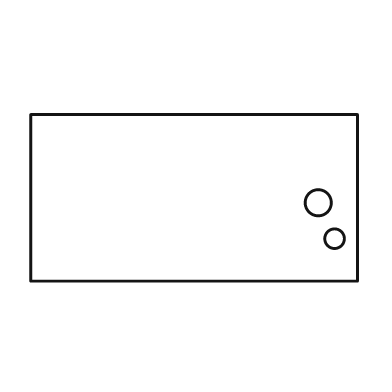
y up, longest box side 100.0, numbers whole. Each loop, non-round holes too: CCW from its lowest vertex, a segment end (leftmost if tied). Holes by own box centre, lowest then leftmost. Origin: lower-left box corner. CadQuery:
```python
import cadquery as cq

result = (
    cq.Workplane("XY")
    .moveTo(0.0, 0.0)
    .lineTo(100.0, 0.0)
    .lineTo(100.0, 51.0)
    .lineTo(0.0, 51.0)
    .close()
    .moveTo(93.0, 13.0)
    .circle(3.0)
    .moveTo(88.0, 24.0)
    .circle(4.0)
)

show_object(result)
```